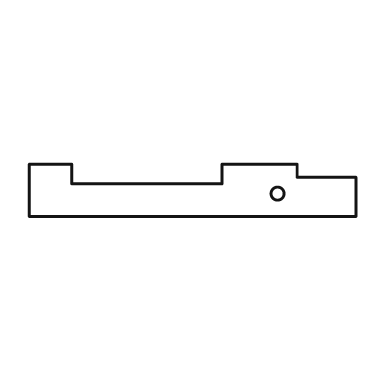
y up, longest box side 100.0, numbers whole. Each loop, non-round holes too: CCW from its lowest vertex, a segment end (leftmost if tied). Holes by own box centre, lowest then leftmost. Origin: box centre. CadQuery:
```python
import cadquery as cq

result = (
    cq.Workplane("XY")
    .moveTo(-50.0, -8.0)
    .lineTo(50.0, -8.0)
    .lineTo(50.0, 4.0)
    .lineTo(32.0, 4.0)
    .lineTo(32.0, 8.0)
    .lineTo(9.0, 8.0)
    .lineTo(9.0, 2.0)
    .lineTo(-37.0, 2.0)
    .lineTo(-37.0, 8.0)
    .lineTo(-50.0, 8.0)
    .close()
    .moveTo(26.0, -1.0)
    .circle(2.0)
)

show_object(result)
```